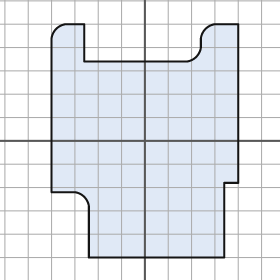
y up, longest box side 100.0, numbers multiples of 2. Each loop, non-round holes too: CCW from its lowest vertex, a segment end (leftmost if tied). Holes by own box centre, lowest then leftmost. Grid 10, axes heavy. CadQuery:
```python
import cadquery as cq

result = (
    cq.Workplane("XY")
    .moveTo(-24.0, -50.0)
    .lineTo(34.0, -50.0)
    .lineTo(34.0, -18.0)
    .lineTo(40.0, -18.0)
    .lineTo(40.0, 50.0)
    .lineTo(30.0, 50.0)
    .threePointArc((26.0, 48.0), (24.0, 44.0))
    .lineTo(24.0, 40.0)
    .threePointArc((22.0, 36.0), (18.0, 34.0))
    .lineTo(-26.0, 34.0)
    .lineTo(-26.0, 50.0)
    .lineTo(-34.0, 50.0)
    .threePointArc((-38.0, 48.0), (-40.0, 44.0))
    .lineTo(-40.0, -22.0)
    .lineTo(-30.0, -22.0)
    .threePointArc((-26.0, -24.0), (-24.0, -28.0))
    .close()
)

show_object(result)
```